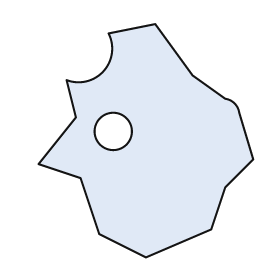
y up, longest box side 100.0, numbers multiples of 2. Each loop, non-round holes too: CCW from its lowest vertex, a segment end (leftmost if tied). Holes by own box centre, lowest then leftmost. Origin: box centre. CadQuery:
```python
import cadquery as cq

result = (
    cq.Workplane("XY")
    .moveTo(0.0, -50.0)
    .lineTo(28.0, -38.0)
    .lineTo(34.0, -20.0)
    .lineTo(46.0, -8.0)
    .lineTo(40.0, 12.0)
    .threePointArc((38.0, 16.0), (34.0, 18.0))
    .lineTo(20.0, 28.0)
    .lineTo(4.0, 50.0)
    .lineTo(-16.0, 46.0)
    .threePointArc((-18.0, 30.0), (-34.0, 26.0))
    .lineTo(-30.0, 10.0)
    .lineTo(-46.0, -10.0)
    .lineTo(-28.0, -16.0)
    .lineTo(-20.0, -40.0)
    .close()
    .moveTo(-14.0, 4.0)
    .circle(8.0)
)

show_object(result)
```